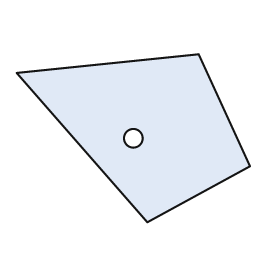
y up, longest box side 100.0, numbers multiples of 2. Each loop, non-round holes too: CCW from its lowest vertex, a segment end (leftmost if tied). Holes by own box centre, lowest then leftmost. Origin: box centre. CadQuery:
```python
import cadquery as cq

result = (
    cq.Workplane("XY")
    .moveTo(6.0, -36.0)
    .lineTo(50.0, -12.0)
    .lineTo(28.0, 36.0)
    .lineTo(-50.0, 28.0)
    .close()
    .moveTo(0.0, 0.0)
    .circle(4.0)
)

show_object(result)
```